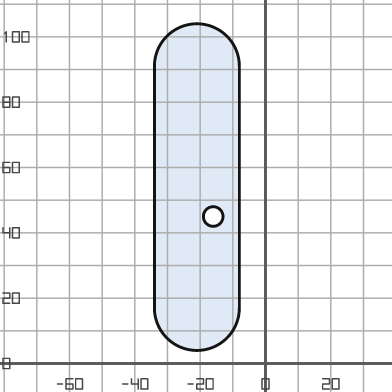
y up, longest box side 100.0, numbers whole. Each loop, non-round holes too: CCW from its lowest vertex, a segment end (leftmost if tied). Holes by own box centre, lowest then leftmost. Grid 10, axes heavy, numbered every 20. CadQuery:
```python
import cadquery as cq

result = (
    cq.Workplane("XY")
    .moveTo(-34.0, 17.0)
    .threePointArc((-21.0, 4.0), (-8.0, 17.0))
    .lineTo(-8.0, 91.0)
    .threePointArc((-21.0, 104.0), (-34.0, 91.0))
    .close()
    .moveTo(-16.0, 45.0)
    .circle(3.0)
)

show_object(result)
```